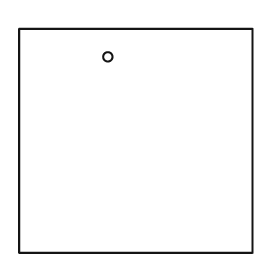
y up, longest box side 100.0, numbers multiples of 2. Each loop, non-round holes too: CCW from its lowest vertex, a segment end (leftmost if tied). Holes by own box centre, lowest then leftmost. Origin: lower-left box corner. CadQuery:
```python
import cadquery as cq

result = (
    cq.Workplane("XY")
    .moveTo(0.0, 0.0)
    .lineTo(100.0, 0.0)
    .lineTo(100.0, 96.0)
    .lineTo(0.0, 96.0)
    .close()
    .moveTo(38.0, 84.0)
    .circle(2.0)
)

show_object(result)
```